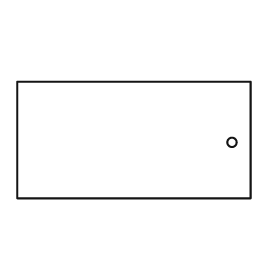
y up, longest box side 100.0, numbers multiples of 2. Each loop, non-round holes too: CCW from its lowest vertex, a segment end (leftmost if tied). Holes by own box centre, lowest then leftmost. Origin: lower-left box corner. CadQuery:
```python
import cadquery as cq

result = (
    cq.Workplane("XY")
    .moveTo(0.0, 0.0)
    .lineTo(100.0, 0.0)
    .lineTo(100.0, 50.0)
    .lineTo(0.0, 50.0)
    .close()
    .moveTo(92.0, 24.0)
    .circle(2.0)
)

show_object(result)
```